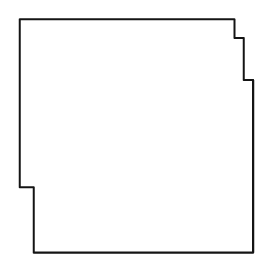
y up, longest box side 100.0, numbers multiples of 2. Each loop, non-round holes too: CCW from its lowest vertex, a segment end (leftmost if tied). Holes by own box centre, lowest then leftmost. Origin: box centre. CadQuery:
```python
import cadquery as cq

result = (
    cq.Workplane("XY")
    .moveTo(-44.0, -50.0)
    .lineTo(50.0, -50.0)
    .lineTo(50.0, 24.0)
    .lineTo(46.0, 24.0)
    .lineTo(46.0, 42.0)
    .lineTo(42.0, 42.0)
    .lineTo(42.0, 50.0)
    .lineTo(-50.0, 50.0)
    .lineTo(-50.0, -22.0)
    .lineTo(-44.0, -22.0)
    .close()
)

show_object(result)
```